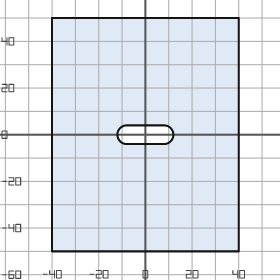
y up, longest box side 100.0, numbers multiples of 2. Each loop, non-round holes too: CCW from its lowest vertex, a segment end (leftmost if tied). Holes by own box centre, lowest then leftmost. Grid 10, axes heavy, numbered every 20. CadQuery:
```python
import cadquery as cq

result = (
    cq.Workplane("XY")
    .moveTo(-40.0, -50.0)
    .lineTo(40.0, -50.0)
    .lineTo(40.0, 50.0)
    .lineTo(-40.0, 50.0)
    .close()
    .moveTo(-8.0, -4.0)
    .lineTo(8.0, -4.0)
    .threePointArc((12.0, 0.0), (8.0, 4.0))
    .lineTo(-8.0, 4.0)
    .threePointArc((-12.0, 0.0), (-8.0, -4.0))
    .close()
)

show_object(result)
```